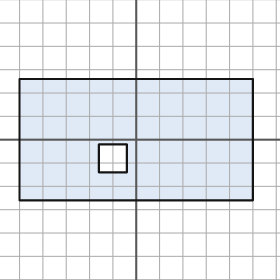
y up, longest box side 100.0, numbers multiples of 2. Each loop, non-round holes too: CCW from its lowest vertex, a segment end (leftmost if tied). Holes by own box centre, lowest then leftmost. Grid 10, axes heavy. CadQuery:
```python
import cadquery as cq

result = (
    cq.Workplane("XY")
    .moveTo(-50.0, -26.0)
    .lineTo(50.0, -26.0)
    .lineTo(50.0, 26.0)
    .lineTo(-50.0, 26.0)
    .close()
    .moveTo(-16.0, -14.0)
    .lineTo(-4.0, -14.0)
    .lineTo(-4.0, -2.0)
    .lineTo(-16.0, -2.0)
    .close()
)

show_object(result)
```